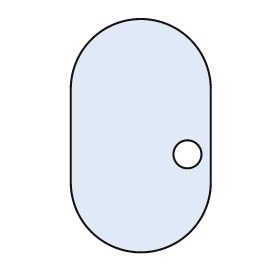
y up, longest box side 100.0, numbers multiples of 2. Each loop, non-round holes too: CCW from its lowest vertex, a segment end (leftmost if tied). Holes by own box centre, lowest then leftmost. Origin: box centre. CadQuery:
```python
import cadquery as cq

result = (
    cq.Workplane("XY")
    .moveTo(-30.0, -20.0)
    .threePointArc((0.0, -50.0), (30.0, -20.0))
    .lineTo(30.0, 20.0)
    .threePointArc((0.0, 50.0), (-30.0, 20.0))
    .close()
    .moveTo(20.0, -8.0)
    .circle(6.0)
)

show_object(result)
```